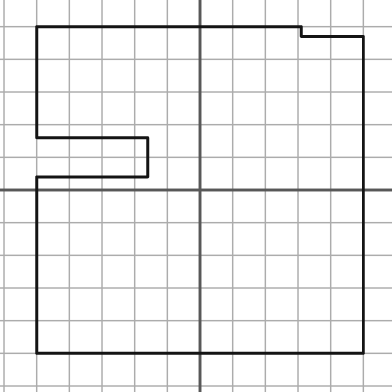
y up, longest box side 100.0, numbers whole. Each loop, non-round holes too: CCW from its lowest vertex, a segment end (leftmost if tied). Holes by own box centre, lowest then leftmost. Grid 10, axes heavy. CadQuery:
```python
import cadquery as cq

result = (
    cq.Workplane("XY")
    .moveTo(-50.0, -50.0)
    .lineTo(50.0, -50.0)
    .lineTo(50.0, 47.0)
    .lineTo(31.0, 47.0)
    .lineTo(31.0, 50.0)
    .lineTo(-50.0, 50.0)
    .lineTo(-50.0, 16.0)
    .lineTo(-16.0, 16.0)
    .lineTo(-16.0, 4.0)
    .lineTo(-50.0, 4.0)
    .close()
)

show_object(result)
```